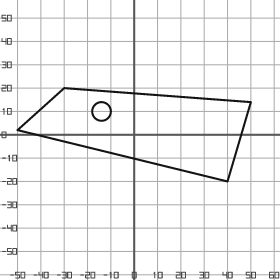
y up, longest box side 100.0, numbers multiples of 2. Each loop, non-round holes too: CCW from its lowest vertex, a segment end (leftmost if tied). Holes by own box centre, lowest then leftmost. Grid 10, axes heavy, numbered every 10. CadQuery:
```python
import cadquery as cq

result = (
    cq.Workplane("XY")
    .moveTo(40.0, -20.0)
    .lineTo(50.0, 14.0)
    .lineTo(-30.0, 20.0)
    .lineTo(-50.0, 2.0)
    .close()
    .moveTo(-14.0, 10.0)
    .circle(4.0)
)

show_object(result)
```